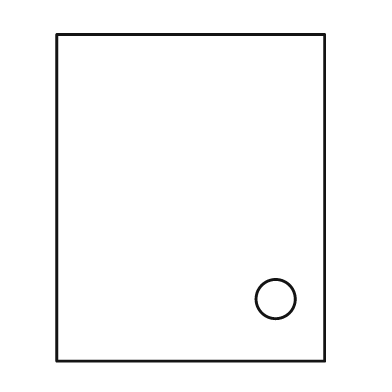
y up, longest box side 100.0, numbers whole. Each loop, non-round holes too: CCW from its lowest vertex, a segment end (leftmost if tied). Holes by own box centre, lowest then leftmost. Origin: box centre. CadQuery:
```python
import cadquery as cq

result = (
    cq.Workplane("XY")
    .moveTo(-41.0, -50.0)
    .lineTo(41.0, -50.0)
    .lineTo(41.0, 50.0)
    .lineTo(-41.0, 50.0)
    .close()
    .moveTo(26.0, -31.0)
    .circle(6.0)
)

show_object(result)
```